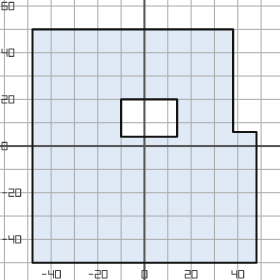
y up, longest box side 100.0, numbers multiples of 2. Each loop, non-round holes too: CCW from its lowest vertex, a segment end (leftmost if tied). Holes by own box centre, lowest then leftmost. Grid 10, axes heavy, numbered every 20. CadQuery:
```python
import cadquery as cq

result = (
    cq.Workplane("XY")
    .moveTo(-48.0, -50.0)
    .lineTo(48.0, -50.0)
    .lineTo(48.0, 6.0)
    .lineTo(38.0, 6.0)
    .lineTo(38.0, 50.0)
    .lineTo(-48.0, 50.0)
    .close()
    .moveTo(-10.0, 4.0)
    .lineTo(14.0, 4.0)
    .lineTo(14.0, 20.0)
    .lineTo(-10.0, 20.0)
    .close()
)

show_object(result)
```